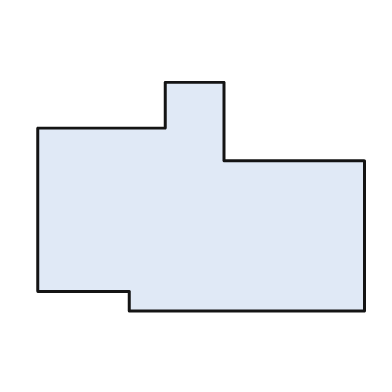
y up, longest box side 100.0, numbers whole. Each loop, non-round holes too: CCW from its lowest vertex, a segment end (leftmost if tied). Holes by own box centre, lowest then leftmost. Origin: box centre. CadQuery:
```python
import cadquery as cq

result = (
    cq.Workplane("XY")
    .moveTo(-22.0, -35.0)
    .lineTo(50.0, -35.0)
    .lineTo(50.0, 11.0)
    .lineTo(7.0, 11.0)
    .lineTo(7.0, 35.0)
    .lineTo(-11.0, 35.0)
    .lineTo(-11.0, 21.0)
    .lineTo(-50.0, 21.0)
    .lineTo(-50.0, -29.0)
    .lineTo(-22.0, -29.0)
    .close()
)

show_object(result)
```